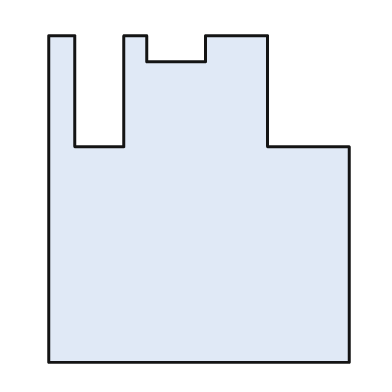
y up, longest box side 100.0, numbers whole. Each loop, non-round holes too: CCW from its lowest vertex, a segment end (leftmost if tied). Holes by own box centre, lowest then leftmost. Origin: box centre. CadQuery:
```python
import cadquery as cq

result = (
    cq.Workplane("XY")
    .moveTo(-46.0, -50.0)
    .lineTo(46.0, -50.0)
    .lineTo(46.0, 16.0)
    .lineTo(21.0, 16.0)
    .lineTo(21.0, 50.0)
    .lineTo(2.0, 50.0)
    .lineTo(2.0, 42.0)
    .lineTo(-16.0, 42.0)
    .lineTo(-16.0, 50.0)
    .lineTo(-23.0, 50.0)
    .lineTo(-23.0, 16.0)
    .lineTo(-38.0, 16.0)
    .lineTo(-38.0, 50.0)
    .lineTo(-46.0, 50.0)
    .close()
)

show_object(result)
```